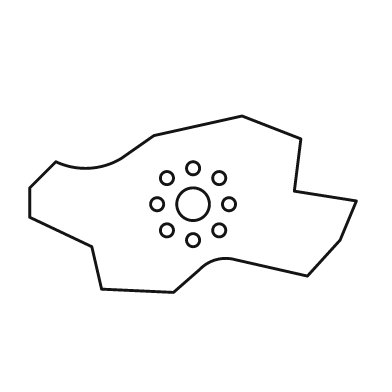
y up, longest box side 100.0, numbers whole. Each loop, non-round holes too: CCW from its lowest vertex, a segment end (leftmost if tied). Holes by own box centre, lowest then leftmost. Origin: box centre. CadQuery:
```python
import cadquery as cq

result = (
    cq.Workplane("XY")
    .moveTo(-6.0, -27.0)
    .lineTo(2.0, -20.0)
    .threePointArc((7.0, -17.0), (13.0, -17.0))
    .lineTo(35.0, -22.0)
    .lineTo(45.0, -11.0)
    .lineTo(50.0, 1.0)
    .lineTo(31.0, 4.0)
    .lineTo(33.0, 20.0)
    .lineTo(15.0, 27.0)
    .lineTo(-12.0, 21.0)
    .lineTo(-22.0, 14.0)
    .threePointArc((-32.0, 11.0), (-42.0, 13.0))
    .lineTo(-50.0, 5.0)
    .lineTo(-50.0, -4.0)
    .lineTo(-31.0, -13.0)
    .lineTo(-28.0, -26.0)
    .close()
    .moveTo(0.0, -11.0)
    .circle(2.0)
    .moveTo(-8.0, -8.0)
    .circle(2.0)
    .moveTo(8.0, -8.0)
    .circle(2.0)
    .moveTo(-11.0, 0.0)
    .circle(2.0)
    .moveTo(0.0, 0.0)
    .circle(5.0)
    .moveTo(11.0, 0.0)
    .circle(2.0)
    .moveTo(-8.0, 8.0)
    .circle(2.0)
    .moveTo(8.0, 8.0)
    .circle(2.0)
    .moveTo(0.0, 11.0)
    .circle(2.0)
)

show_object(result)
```